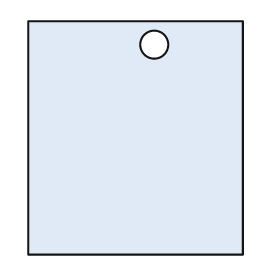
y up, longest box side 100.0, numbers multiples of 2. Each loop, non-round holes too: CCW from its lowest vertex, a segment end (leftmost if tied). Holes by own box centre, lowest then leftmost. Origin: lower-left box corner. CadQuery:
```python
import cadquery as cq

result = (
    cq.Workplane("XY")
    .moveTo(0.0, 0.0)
    .lineTo(92.0, 0.0)
    .lineTo(92.0, 100.0)
    .lineTo(0.0, 100.0)
    .close()
    .moveTo(54.0, 90.0)
    .circle(6.0)
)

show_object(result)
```